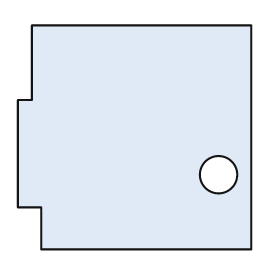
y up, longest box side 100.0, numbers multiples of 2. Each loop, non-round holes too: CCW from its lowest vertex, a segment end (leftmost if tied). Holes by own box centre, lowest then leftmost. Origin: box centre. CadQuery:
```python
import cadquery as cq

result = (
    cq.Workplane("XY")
    .moveTo(-40.0, -48.0)
    .lineTo(50.0, -48.0)
    .lineTo(50.0, 48.0)
    .lineTo(-44.0, 48.0)
    .lineTo(-44.0, 16.0)
    .lineTo(-50.0, 16.0)
    .lineTo(-50.0, -30.0)
    .lineTo(-40.0, -30.0)
    .close()
    .moveTo(36.0, -16.0)
    .circle(8.0)
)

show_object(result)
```